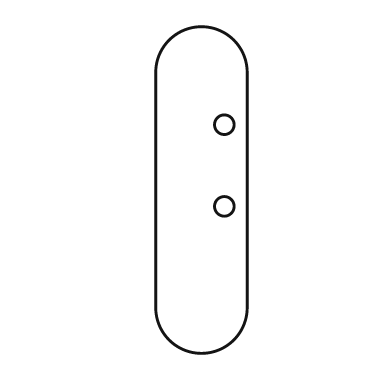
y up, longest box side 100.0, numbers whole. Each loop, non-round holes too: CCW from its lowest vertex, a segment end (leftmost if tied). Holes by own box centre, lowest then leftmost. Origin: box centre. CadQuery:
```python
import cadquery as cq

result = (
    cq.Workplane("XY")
    .moveTo(-14.0, -36.0)
    .threePointArc((0.0, -50.0), (14.0, -36.0))
    .lineTo(14.0, 36.0)
    .threePointArc((0.0, 50.0), (-14.0, 36.0))
    .close()
    .moveTo(7.0, -5.0)
    .circle(3.0)
    .moveTo(7.0, 20.0)
    .circle(3.0)
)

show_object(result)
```